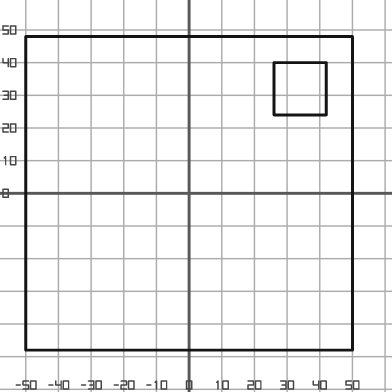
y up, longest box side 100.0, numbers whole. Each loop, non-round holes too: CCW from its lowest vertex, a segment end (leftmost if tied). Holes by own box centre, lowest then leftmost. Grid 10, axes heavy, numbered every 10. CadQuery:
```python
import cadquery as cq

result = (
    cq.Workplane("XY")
    .moveTo(-50.0, -48.0)
    .lineTo(50.0, -48.0)
    .lineTo(50.0, 48.0)
    .lineTo(-50.0, 48.0)
    .close()
    .moveTo(26.0, 24.0)
    .lineTo(42.0, 24.0)
    .lineTo(42.0, 40.0)
    .lineTo(26.0, 40.0)
    .close()
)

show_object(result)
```